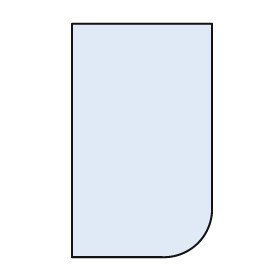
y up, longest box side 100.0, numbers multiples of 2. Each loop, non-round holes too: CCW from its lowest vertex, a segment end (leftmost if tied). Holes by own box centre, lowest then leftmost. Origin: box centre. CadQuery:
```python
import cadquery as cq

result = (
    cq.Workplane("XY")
    .moveTo(-30.0, -50.0)
    .lineTo(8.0, -50.0)
    .threePointArc((24.0, -44.0), (30.0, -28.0))
    .lineTo(30.0, 50.0)
    .lineTo(-30.0, 50.0)
    .close()
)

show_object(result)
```